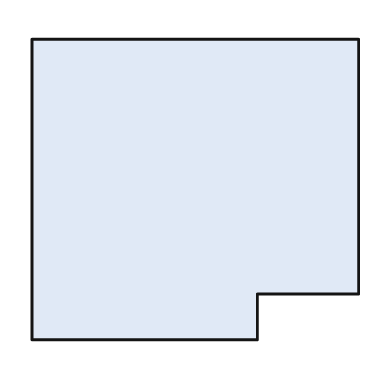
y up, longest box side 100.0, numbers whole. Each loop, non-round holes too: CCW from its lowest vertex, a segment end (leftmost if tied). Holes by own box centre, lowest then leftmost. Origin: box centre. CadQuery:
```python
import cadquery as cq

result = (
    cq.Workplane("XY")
    .moveTo(-50.0, -46.0)
    .lineTo(19.0, -46.0)
    .lineTo(19.0, -32.0)
    .lineTo(50.0, -32.0)
    .lineTo(50.0, 46.0)
    .lineTo(-50.0, 46.0)
    .close()
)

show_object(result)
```